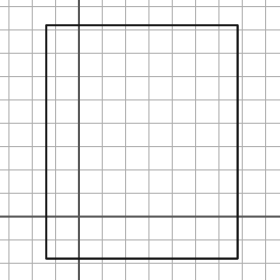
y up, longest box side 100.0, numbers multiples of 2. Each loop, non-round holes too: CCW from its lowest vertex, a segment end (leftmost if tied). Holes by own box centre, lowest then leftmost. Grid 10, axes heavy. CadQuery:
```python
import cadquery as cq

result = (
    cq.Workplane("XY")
    .moveTo(-14.0, -18.0)
    .lineTo(68.0, -18.0)
    .lineTo(68.0, 82.0)
    .lineTo(-14.0, 82.0)
    .close()
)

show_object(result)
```